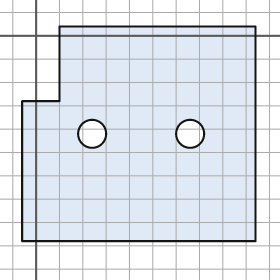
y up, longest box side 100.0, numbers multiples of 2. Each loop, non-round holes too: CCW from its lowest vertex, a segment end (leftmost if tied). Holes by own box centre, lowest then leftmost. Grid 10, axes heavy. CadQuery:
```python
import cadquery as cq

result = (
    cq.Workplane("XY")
    .moveTo(-6.0, -88.0)
    .lineTo(94.0, -88.0)
    .lineTo(94.0, 4.0)
    .lineTo(10.0, 4.0)
    .lineTo(10.0, -28.0)
    .lineTo(-6.0, -28.0)
    .close()
    .moveTo(24.0, -42.0)
    .circle(6.0)
    .moveTo(66.0, -42.0)
    .circle(6.0)
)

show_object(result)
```